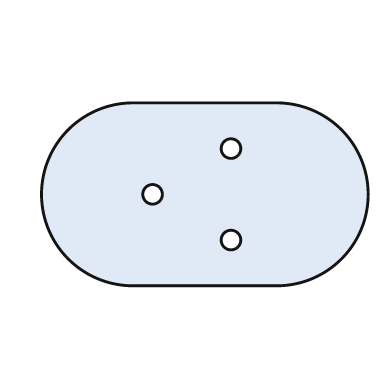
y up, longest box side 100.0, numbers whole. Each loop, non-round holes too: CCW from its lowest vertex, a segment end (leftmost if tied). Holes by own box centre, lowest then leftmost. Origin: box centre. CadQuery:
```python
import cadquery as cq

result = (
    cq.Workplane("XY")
    .moveTo(-22.0, -28.0)
    .lineTo(22.0, -28.0)
    .threePointArc((50.0, 0.0), (22.0, 28.0))
    .lineTo(-22.0, 28.0)
    .threePointArc((-50.0, 0.0), (-22.0, -28.0))
    .close()
    .moveTo(8.0, -14.0)
    .circle(3.0)
    .moveTo(-16.0, 0.0)
    .circle(3.0)
    .moveTo(8.0, 14.0)
    .circle(3.0)
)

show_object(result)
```